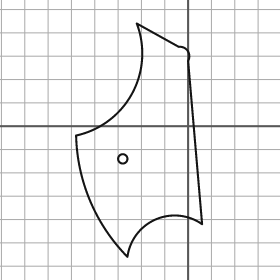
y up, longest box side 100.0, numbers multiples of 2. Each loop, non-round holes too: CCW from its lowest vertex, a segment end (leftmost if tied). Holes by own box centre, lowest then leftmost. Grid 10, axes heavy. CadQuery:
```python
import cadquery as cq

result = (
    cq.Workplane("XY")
    .moveTo(-26.0, -56.0)
    .threePointArc((-14.0, -40.0), (6.0, -42.0))
    .lineTo(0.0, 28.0)
    .threePointArc((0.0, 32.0), (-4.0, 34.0))
    .lineTo(-22.0, 44.0)
    .threePointArc((-24.0, 14.0), (-48.0, -4.0))
    .threePointArc((-42.0, -32.0), (-26.0, -56.0))
    .close()
    .moveTo(-28.0, -14.0)
    .circle(2.0)
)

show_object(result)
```